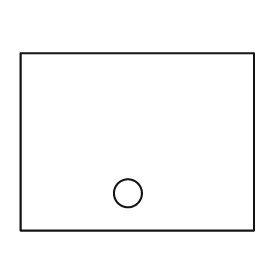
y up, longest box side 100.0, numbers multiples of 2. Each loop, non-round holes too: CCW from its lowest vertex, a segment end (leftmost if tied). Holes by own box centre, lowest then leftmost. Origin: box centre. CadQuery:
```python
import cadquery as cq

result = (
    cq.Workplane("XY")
    .moveTo(-50.0, -38.0)
    .lineTo(50.0, -38.0)
    .lineTo(50.0, 38.0)
    .lineTo(-50.0, 38.0)
    .close()
    .moveTo(-4.0, -22.0)
    .circle(6.0)
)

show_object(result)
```